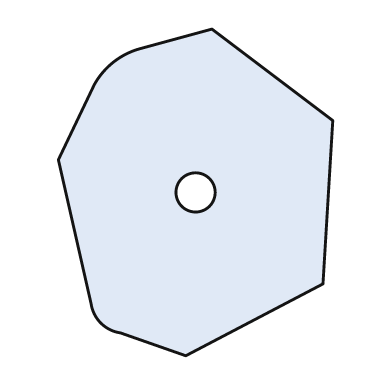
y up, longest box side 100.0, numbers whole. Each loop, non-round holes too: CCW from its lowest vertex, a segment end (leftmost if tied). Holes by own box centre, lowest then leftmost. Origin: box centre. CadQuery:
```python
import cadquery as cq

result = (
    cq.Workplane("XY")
    .moveTo(-3.0, -50.0)
    .lineTo(39.0, -28.0)
    .lineTo(42.0, 22.0)
    .lineTo(5.0, 50.0)
    .lineTo(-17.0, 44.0)
    .threePointArc((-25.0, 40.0), (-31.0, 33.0))
    .lineTo(-42.0, 10.0)
    .lineTo(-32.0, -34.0)
    .threePointArc((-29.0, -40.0), (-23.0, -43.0))
    .close()
    .moveTo(0.0, 0.0)
    .circle(6.0)
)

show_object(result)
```